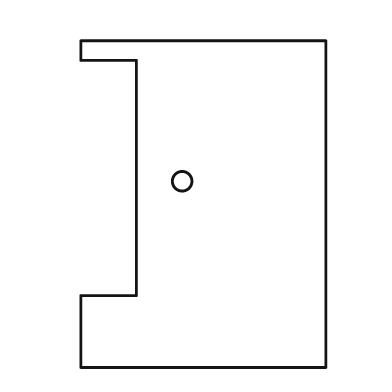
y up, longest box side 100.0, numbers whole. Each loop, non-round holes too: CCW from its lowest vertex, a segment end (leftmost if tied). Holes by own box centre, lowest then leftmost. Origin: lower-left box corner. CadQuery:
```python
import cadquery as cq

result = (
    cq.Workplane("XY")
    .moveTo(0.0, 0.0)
    .lineTo(75.0, 0.0)
    .lineTo(75.0, 100.0)
    .lineTo(0.0, 100.0)
    .lineTo(0.0, 94.0)
    .lineTo(17.0, 94.0)
    .lineTo(17.0, 22.0)
    .lineTo(0.0, 22.0)
    .close()
    .moveTo(31.0, 57.0)
    .circle(3.0)
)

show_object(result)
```